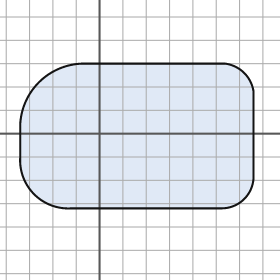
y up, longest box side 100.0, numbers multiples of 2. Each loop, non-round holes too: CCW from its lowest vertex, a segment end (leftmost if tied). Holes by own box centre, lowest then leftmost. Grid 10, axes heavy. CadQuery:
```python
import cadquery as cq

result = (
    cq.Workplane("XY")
    .moveTo(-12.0, -32.0)
    .lineTo(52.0, -32.0)
    .threePointArc((62.0, -28.0), (66.0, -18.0))
    .lineTo(66.0, 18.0)
    .threePointArc((62.0, 26.0), (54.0, 30.0))
    .lineTo(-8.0, 30.0)
    .threePointArc((-26.0, 22.0), (-34.0, 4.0))
    .lineTo(-34.0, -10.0)
    .threePointArc((-28.0, -26.0), (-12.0, -32.0))
    .close()
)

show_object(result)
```